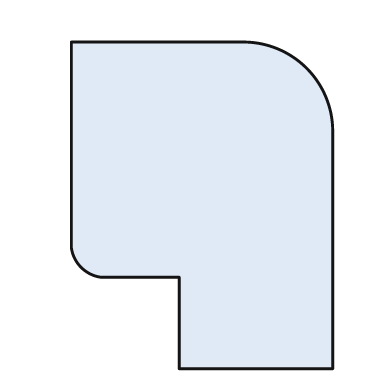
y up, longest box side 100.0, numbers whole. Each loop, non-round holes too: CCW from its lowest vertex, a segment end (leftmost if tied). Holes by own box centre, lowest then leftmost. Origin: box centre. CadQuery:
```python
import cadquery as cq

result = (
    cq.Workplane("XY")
    .moveTo(-7.0, -50.0)
    .lineTo(40.0, -50.0)
    .lineTo(40.0, 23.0)
    .threePointArc((32.0, 42.0), (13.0, 50.0))
    .lineTo(-40.0, 50.0)
    .lineTo(-40.0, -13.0)
    .threePointArc((-37.0, -19.0), (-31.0, -22.0))
    .lineTo(-7.0, -22.0)
    .close()
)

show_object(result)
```